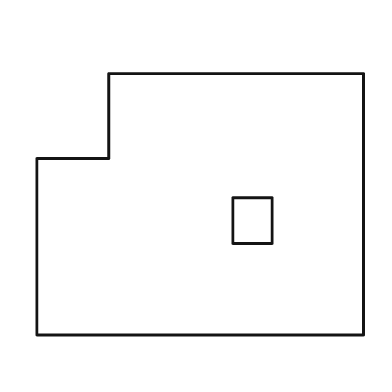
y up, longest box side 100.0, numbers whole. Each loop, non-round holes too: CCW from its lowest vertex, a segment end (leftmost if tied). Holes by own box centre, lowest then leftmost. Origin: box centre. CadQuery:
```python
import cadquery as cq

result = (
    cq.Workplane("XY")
    .moveTo(-50.0, -40.0)
    .lineTo(50.0, -40.0)
    .lineTo(50.0, 40.0)
    .lineTo(-28.0, 40.0)
    .lineTo(-28.0, 14.0)
    .lineTo(-50.0, 14.0)
    .close()
    .moveTo(10.0, -12.0)
    .lineTo(22.0, -12.0)
    .lineTo(22.0, 2.0)
    .lineTo(10.0, 2.0)
    .close()
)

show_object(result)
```